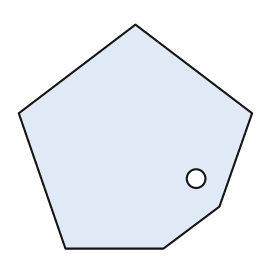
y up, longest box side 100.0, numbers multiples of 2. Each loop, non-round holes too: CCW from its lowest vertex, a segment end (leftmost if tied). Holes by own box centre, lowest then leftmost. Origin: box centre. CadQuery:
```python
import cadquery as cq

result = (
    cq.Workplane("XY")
    .moveTo(-30.0, -48.0)
    .lineTo(12.0, -48.0)
    .lineTo(36.0, -30.0)
    .lineTo(50.0, 10.0)
    .lineTo(0.0, 48.0)
    .lineTo(-50.0, 10.0)
    .close()
    .moveTo(26.0, -18.0)
    .circle(4.0)
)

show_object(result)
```